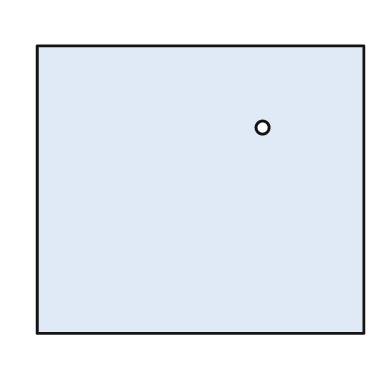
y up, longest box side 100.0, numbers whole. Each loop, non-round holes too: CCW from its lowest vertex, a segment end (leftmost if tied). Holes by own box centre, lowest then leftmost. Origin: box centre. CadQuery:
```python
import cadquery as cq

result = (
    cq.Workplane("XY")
    .moveTo(-50.0, -44.0)
    .lineTo(50.0, -44.0)
    .lineTo(50.0, 44.0)
    .lineTo(-50.0, 44.0)
    .close()
    .moveTo(19.0, 19.0)
    .circle(2.0)
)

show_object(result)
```